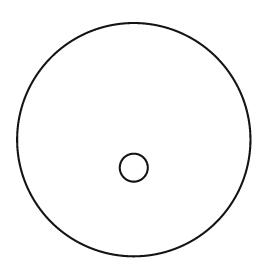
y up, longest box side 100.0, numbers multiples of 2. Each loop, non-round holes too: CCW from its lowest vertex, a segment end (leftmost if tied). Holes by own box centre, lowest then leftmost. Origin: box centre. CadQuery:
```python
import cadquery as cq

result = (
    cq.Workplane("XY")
    .moveTo(0.0, 0.0)
    .circle(50.0)
    .moveTo(0.0, -12.0)
    .circle(6.0)
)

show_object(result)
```